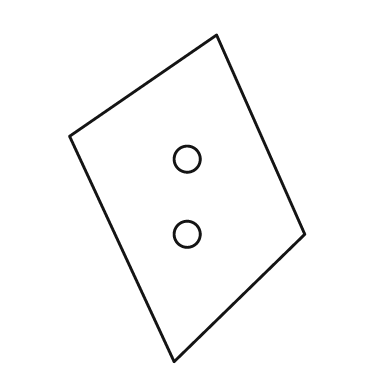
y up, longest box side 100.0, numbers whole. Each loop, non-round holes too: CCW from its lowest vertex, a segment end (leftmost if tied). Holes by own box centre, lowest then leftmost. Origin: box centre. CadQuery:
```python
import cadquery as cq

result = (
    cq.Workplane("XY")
    .moveTo(-4.0, -50.0)
    .lineTo(36.0, -11.0)
    .lineTo(9.0, 50.0)
    .lineTo(-36.0, 19.0)
    .close()
    .moveTo(0.0, -11.0)
    .circle(4.0)
    .moveTo(0.0, 12.0)
    .circle(4.0)
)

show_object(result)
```